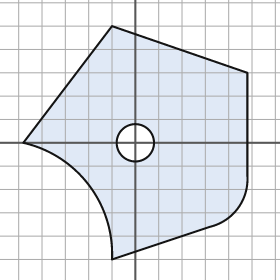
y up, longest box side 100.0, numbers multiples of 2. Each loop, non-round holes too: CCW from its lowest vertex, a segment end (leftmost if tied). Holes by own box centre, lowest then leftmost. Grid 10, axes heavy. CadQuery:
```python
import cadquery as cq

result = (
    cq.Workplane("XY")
    .moveTo(-10.0, -50.0)
    .lineTo(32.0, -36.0)
    .threePointArc((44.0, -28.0), (48.0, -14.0))
    .lineTo(48.0, 30.0)
    .lineTo(-10.0, 50.0)
    .lineTo(-48.0, 0.0)
    .threePointArc((-20.0, -18.0), (-10.0, -50.0))
    .close()
    .moveTo(0.0, 0.0)
    .circle(8.0)
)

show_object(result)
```